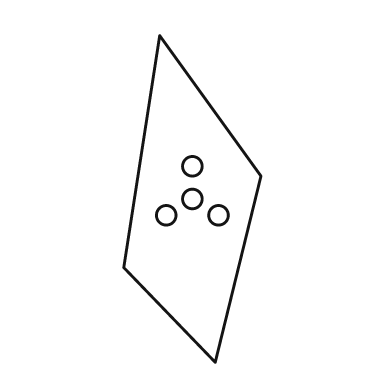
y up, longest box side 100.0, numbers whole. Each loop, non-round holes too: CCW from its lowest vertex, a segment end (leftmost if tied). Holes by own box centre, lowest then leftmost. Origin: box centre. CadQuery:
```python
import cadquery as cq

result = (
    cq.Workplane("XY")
    .moveTo(7.0, -50.0)
    .lineTo(21.0, 7.0)
    .lineTo(-10.0, 50.0)
    .lineTo(-21.0, -21.0)
    .close()
    .moveTo(-8.0, -5.0)
    .circle(3.0)
    .moveTo(8.0, -5.0)
    .circle(3.0)
    .moveTo(0.0, 0.0)
    .circle(3.0)
    .moveTo(0.0, 10.0)
    .circle(3.0)
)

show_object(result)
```